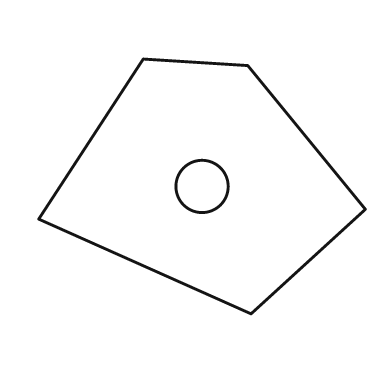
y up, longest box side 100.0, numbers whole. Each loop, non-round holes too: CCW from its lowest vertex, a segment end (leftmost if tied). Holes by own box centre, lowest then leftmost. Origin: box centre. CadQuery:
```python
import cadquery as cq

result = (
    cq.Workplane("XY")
    .moveTo(15.0, -39.0)
    .lineTo(50.0, -7.0)
    .lineTo(14.0, 37.0)
    .lineTo(-18.0, 39.0)
    .lineTo(-50.0, -10.0)
    .close()
    .moveTo(0.0, 0.0)
    .circle(8.0)
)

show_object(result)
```